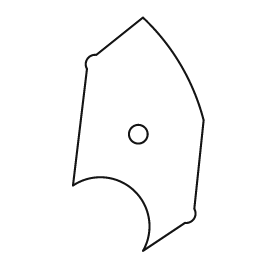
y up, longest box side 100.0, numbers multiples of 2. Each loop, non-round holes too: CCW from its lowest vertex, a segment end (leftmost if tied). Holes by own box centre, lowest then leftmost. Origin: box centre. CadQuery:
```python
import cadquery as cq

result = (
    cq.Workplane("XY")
    .moveTo(2.0, -50.0)
    .lineTo(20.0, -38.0)
    .threePointArc((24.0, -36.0), (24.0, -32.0))
    .lineTo(28.0, 6.0)
    .threePointArc((18.0, 30.0), (2.0, 50.0))
    .lineTo(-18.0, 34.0)
    .threePointArc((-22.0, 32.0), (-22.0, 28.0))
    .lineTo(-28.0, -22.0)
    .threePointArc((-2.0, -24.0), (2.0, -50.0))
    .close()
    .moveTo(0.0, 0.0)
    .circle(4.0)
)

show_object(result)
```